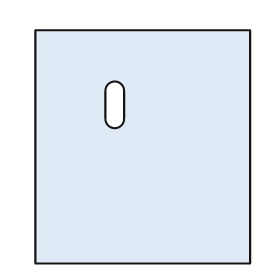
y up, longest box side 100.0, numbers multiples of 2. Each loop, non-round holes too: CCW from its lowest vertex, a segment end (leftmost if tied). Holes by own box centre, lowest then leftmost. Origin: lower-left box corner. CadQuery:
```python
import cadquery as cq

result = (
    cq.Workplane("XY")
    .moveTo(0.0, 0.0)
    .lineTo(92.0, 0.0)
    .lineTo(92.0, 100.0)
    .lineTo(0.0, 100.0)
    .close()
    .moveTo(30.0, 62.0)
    .threePointArc((34.0, 58.0), (38.0, 62.0))
    .lineTo(38.0, 74.0)
    .threePointArc((34.0, 78.0), (30.0, 74.0))
    .close()
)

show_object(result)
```